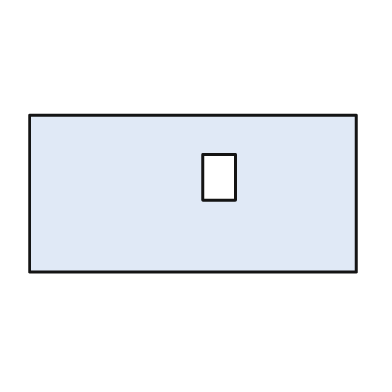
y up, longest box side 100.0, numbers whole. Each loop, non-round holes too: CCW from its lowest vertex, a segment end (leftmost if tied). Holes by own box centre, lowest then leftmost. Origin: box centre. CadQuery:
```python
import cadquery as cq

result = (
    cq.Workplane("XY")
    .moveTo(-50.0, -24.0)
    .lineTo(50.0, -24.0)
    .lineTo(50.0, 24.0)
    .lineTo(-50.0, 24.0)
    .close()
    .moveTo(3.0, -2.0)
    .lineTo(13.0, -2.0)
    .lineTo(13.0, 12.0)
    .lineTo(3.0, 12.0)
    .close()
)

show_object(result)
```